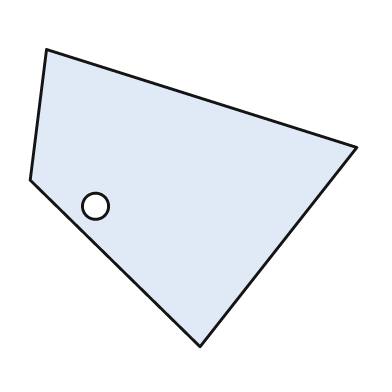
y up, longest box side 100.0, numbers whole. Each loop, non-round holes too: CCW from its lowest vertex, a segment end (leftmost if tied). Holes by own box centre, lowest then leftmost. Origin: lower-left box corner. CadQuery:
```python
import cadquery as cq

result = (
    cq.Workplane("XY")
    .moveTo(52.0, 0.0)
    .lineTo(100.0, 61.0)
    .lineTo(5.0, 91.0)
    .lineTo(0.0, 51.0)
    .close()
    .moveTo(20.0, 43.0)
    .circle(4.0)
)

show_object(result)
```